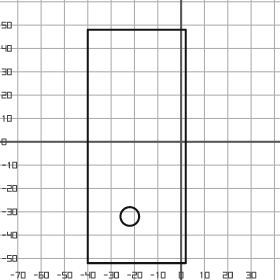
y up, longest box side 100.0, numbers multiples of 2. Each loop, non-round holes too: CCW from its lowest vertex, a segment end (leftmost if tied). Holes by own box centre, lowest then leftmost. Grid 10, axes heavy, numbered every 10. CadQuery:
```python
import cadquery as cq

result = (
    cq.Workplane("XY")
    .moveTo(-40.0, -52.0)
    .lineTo(2.0, -52.0)
    .lineTo(2.0, 48.0)
    .lineTo(-40.0, 48.0)
    .close()
    .moveTo(-22.0, -32.0)
    .circle(4.0)
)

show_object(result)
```